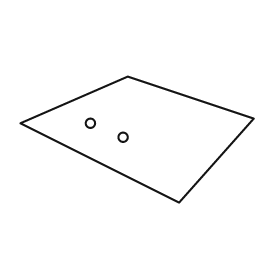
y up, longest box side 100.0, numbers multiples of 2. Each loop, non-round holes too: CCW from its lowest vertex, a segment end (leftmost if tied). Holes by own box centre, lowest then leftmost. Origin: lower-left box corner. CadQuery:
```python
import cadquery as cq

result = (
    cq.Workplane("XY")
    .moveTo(68.0, 0.0)
    .lineTo(100.0, 36.0)
    .lineTo(46.0, 54.0)
    .lineTo(0.0, 34.0)
    .close()
    .moveTo(44.0, 28.0)
    .circle(2.0)
    .moveTo(30.0, 34.0)
    .circle(2.0)
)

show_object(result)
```